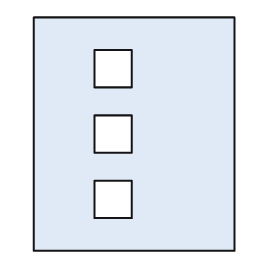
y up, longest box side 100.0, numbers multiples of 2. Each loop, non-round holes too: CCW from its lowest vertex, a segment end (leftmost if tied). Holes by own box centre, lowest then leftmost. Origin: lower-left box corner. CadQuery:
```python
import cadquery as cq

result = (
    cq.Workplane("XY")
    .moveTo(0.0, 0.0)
    .lineTo(86.0, 0.0)
    .lineTo(86.0, 100.0)
    .lineTo(0.0, 100.0)
    .close()
    .moveTo(26.0, 14.0)
    .lineTo(42.0, 14.0)
    .lineTo(42.0, 30.0)
    .lineTo(26.0, 30.0)
    .close()
    .moveTo(26.0, 42.0)
    .lineTo(42.0, 42.0)
    .lineTo(42.0, 58.0)
    .lineTo(26.0, 58.0)
    .close()
    .moveTo(26.0, 70.0)
    .lineTo(42.0, 70.0)
    .lineTo(42.0, 86.0)
    .lineTo(26.0, 86.0)
    .close()
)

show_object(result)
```